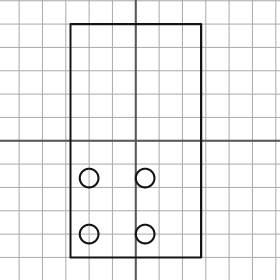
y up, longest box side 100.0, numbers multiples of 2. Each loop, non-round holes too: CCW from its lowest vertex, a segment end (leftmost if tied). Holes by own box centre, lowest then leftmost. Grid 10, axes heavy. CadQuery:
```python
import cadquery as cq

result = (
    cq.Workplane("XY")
    .moveTo(-28.0, -50.0)
    .lineTo(28.0, -50.0)
    .lineTo(28.0, 50.0)
    .lineTo(-28.0, 50.0)
    .close()
    .moveTo(-20.0, -40.0)
    .circle(4.0)
    .moveTo(4.0, -40.0)
    .circle(4.0)
    .moveTo(-20.0, -16.0)
    .circle(4.0)
    .moveTo(4.0, -16.0)
    .circle(4.0)
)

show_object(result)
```